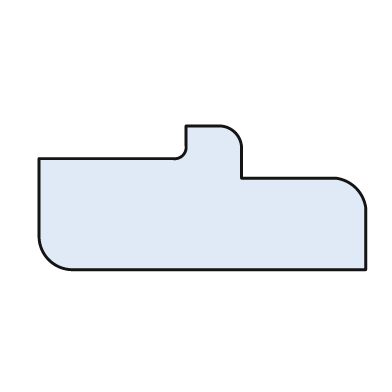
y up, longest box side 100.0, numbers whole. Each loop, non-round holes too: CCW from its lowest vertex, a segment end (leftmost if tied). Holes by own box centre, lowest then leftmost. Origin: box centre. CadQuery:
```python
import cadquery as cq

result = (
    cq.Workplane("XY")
    .moveTo(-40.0, -22.0)
    .lineTo(50.0, -22.0)
    .lineTo(50.0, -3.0)
    .threePointArc((47.0, 3.0), (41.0, 6.0))
    .lineTo(12.0, 6.0)
    .lineTo(12.0, 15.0)
    .threePointArc((10.0, 20.0), (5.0, 22.0))
    .lineTo(-5.0, 22.0)
    .lineTo(-5.0, 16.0)
    .threePointArc((-6.0, 13.0), (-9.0, 12.0))
    .lineTo(-50.0, 12.0)
    .lineTo(-50.0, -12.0)
    .threePointArc((-47.0, -19.0), (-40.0, -22.0))
    .close()
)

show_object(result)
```